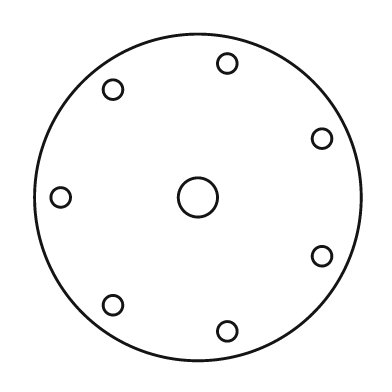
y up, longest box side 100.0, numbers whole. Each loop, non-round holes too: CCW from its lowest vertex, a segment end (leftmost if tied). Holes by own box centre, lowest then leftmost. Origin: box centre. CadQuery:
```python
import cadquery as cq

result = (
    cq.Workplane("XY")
    .moveTo(0.0, 0.0)
    .circle(50.0)
    .moveTo(9.0, -41.0)
    .circle(3.0)
    .moveTo(-26.0, -33.0)
    .circle(3.0)
    .moveTo(38.0, -18.0)
    .circle(3.0)
    .moveTo(-42.0, 0.0)
    .circle(3.0)
    .moveTo(0.0, 0.0)
    .circle(6.0)
    .moveTo(38.0, 18.0)
    .circle(3.0)
    .moveTo(-26.0, 33.0)
    .circle(3.0)
    .moveTo(9.0, 41.0)
    .circle(3.0)
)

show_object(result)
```